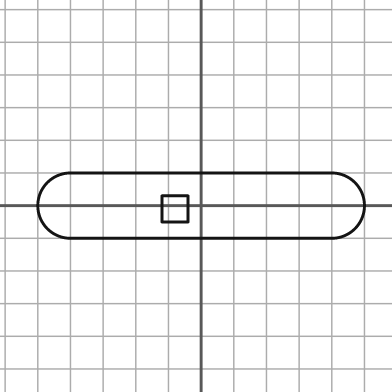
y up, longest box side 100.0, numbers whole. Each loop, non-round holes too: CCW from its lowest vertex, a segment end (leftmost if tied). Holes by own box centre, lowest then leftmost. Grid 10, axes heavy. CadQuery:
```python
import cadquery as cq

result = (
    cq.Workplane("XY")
    .moveTo(-40.0, -10.0)
    .lineTo(40.0, -10.0)
    .threePointArc((50.0, 0.0), (40.0, 10.0))
    .lineTo(-40.0, 10.0)
    .threePointArc((-50.0, 0.0), (-40.0, -10.0))
    .close()
    .moveTo(-12.0, -5.0)
    .lineTo(-4.0, -5.0)
    .lineTo(-4.0, 3.0)
    .lineTo(-12.0, 3.0)
    .close()
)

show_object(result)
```